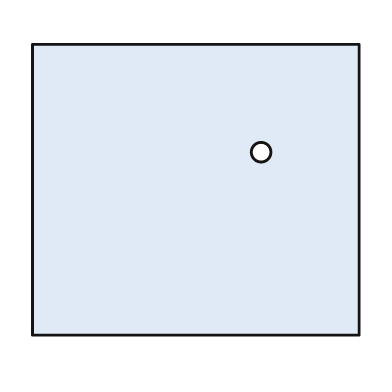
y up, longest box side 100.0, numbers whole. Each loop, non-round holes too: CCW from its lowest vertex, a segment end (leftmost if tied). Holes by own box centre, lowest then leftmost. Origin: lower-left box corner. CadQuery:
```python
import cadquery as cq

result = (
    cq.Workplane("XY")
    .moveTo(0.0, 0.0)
    .lineTo(100.0, 0.0)
    .lineTo(100.0, 89.0)
    .lineTo(0.0, 89.0)
    .close()
    .moveTo(70.0, 56.0)
    .circle(3.0)
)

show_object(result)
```